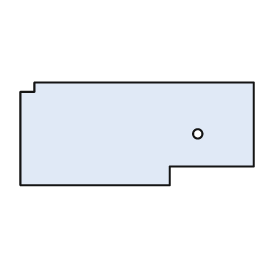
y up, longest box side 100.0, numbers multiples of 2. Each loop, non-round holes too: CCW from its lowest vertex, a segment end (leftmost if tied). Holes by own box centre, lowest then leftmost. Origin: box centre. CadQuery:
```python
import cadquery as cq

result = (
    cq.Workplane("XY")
    .moveTo(-50.0, -22.0)
    .lineTo(14.0, -22.0)
    .lineTo(14.0, -14.0)
    .lineTo(50.0, -14.0)
    .lineTo(50.0, 22.0)
    .lineTo(-44.0, 22.0)
    .lineTo(-44.0, 18.0)
    .lineTo(-50.0, 18.0)
    .close()
    .moveTo(26.0, 0.0)
    .circle(2.0)
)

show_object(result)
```